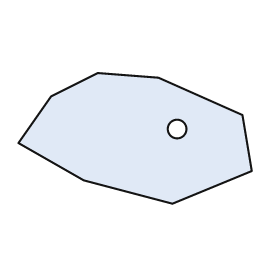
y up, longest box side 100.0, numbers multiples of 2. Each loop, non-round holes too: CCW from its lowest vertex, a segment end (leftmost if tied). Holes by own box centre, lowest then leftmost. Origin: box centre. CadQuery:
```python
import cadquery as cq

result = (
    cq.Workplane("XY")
    .moveTo(16.0, -28.0)
    .lineTo(50.0, -14.0)
    .lineTo(46.0, 10.0)
    .lineTo(10.0, 26.0)
    .lineTo(-16.0, 28.0)
    .lineTo(-36.0, 18.0)
    .lineTo(-50.0, -2.0)
    .lineTo(-22.0, -18.0)
    .close()
    .moveTo(18.0, 4.0)
    .circle(4.0)
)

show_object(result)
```